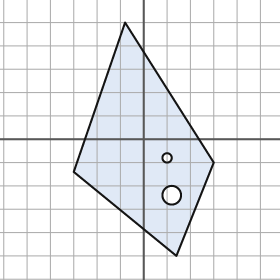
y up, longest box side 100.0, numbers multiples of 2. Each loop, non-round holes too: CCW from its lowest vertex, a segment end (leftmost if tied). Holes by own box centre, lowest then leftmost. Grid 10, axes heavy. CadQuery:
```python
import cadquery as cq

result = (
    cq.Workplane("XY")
    .moveTo(14.0, -50.0)
    .lineTo(30.0, -10.0)
    .lineTo(-8.0, 50.0)
    .lineTo(-30.0, -14.0)
    .close()
    .moveTo(12.0, -24.0)
    .circle(4.0)
    .moveTo(10.0, -8.0)
    .circle(2.0)
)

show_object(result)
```